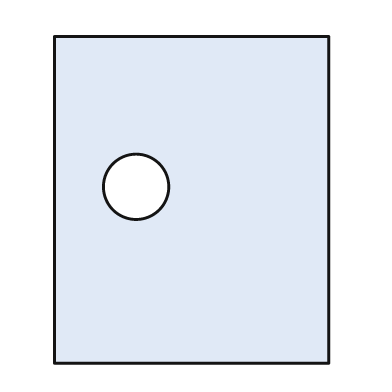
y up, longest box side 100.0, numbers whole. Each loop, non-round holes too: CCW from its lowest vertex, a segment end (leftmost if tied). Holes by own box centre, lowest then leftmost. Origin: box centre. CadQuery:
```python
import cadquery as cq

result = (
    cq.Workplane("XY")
    .moveTo(-42.0, -50.0)
    .lineTo(42.0, -50.0)
    .lineTo(42.0, 50.0)
    .lineTo(-42.0, 50.0)
    .close()
    .moveTo(-17.0, 4.0)
    .circle(10.0)
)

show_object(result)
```